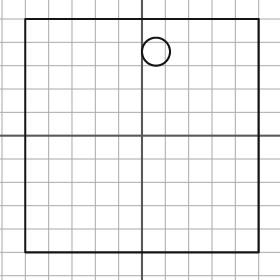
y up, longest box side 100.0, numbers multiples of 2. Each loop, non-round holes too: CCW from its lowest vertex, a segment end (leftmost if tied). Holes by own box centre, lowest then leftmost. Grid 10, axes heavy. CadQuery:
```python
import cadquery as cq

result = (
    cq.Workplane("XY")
    .moveTo(-50.0, -50.0)
    .lineTo(50.0, -50.0)
    .lineTo(50.0, 50.0)
    .lineTo(-50.0, 50.0)
    .close()
    .moveTo(6.0, 36.0)
    .circle(6.0)
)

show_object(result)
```